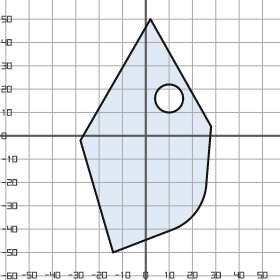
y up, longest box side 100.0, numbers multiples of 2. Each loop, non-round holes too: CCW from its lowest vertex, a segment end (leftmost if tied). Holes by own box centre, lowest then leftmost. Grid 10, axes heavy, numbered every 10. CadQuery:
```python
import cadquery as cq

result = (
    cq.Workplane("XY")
    .moveTo(-14.0, -50.0)
    .lineTo(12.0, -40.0)
    .threePointArc((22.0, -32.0), (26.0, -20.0))
    .lineTo(28.0, 4.0)
    .lineTo(2.0, 50.0)
    .lineTo(-28.0, -2.0)
    .close()
    .moveTo(10.0, 16.0)
    .circle(6.0)
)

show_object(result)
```